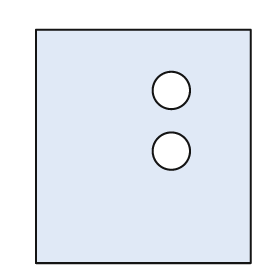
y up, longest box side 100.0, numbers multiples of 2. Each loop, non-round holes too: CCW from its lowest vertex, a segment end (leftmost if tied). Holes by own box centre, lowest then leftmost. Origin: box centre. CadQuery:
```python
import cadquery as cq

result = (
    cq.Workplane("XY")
    .moveTo(-46.0, -50.0)
    .lineTo(46.0, -50.0)
    .lineTo(46.0, 50.0)
    .lineTo(-46.0, 50.0)
    .close()
    .moveTo(12.0, -2.0)
    .circle(8.0)
    .moveTo(12.0, 24.0)
    .circle(8.0)
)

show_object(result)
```